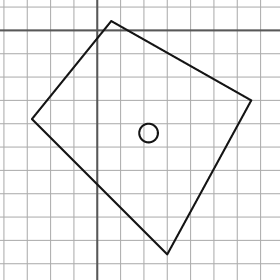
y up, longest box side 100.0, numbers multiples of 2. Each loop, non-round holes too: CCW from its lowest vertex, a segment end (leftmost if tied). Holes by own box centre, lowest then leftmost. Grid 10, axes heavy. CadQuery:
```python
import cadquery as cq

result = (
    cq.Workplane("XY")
    .moveTo(30.0, -96.0)
    .lineTo(66.0, -30.0)
    .lineTo(6.0, 4.0)
    .lineTo(-28.0, -38.0)
    .close()
    .moveTo(22.0, -44.0)
    .circle(4.0)
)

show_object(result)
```